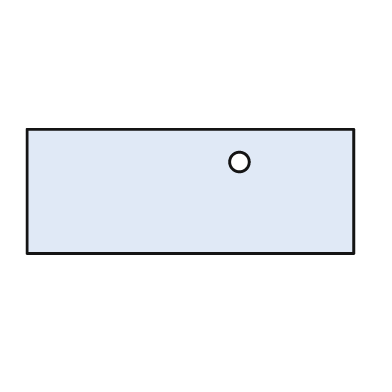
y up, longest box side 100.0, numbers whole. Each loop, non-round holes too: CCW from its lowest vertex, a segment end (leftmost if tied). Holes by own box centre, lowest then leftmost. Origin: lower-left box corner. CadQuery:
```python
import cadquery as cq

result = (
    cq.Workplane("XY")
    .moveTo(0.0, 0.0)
    .lineTo(100.0, 0.0)
    .lineTo(100.0, 38.0)
    .lineTo(0.0, 38.0)
    .close()
    .moveTo(65.0, 28.0)
    .circle(3.0)
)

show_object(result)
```